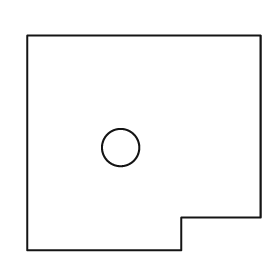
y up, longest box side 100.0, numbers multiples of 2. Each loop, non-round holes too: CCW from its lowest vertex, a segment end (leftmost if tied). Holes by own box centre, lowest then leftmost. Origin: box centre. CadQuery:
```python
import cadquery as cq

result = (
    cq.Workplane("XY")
    .moveTo(-50.0, -46.0)
    .lineTo(16.0, -46.0)
    .lineTo(16.0, -32.0)
    .lineTo(50.0, -32.0)
    .lineTo(50.0, 46.0)
    .lineTo(-50.0, 46.0)
    .close()
    .moveTo(-10.0, -2.0)
    .circle(8.0)
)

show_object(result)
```